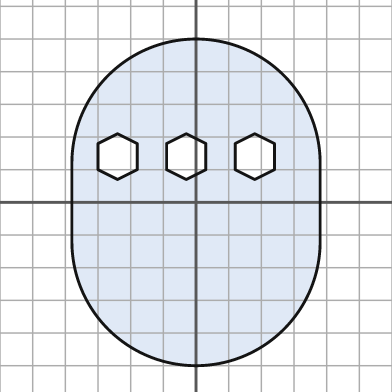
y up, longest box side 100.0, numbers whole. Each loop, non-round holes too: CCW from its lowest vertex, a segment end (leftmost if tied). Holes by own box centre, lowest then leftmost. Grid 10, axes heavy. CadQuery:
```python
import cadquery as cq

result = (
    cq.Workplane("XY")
    .moveTo(-38.0, -12.0)
    .threePointArc((0.0, -50.0), (38.0, -12.0))
    .lineTo(38.0, 12.0)
    .threePointArc((0.0, 50.0), (-38.0, 12.0))
    .close()
    .moveTo(-24.0, 7.0)
    .lineTo(-18.0, 10.0)
    .lineTo(-18.0, 18.0)
    .lineTo(-24.0, 21.0)
    .lineTo(-30.0, 18.0)
    .lineTo(-30.0, 10.0)
    .close()
    .moveTo(-3.0, 7.0)
    .lineTo(3.0, 10.0)
    .lineTo(3.0, 18.0)
    .lineTo(-3.0, 21.0)
    .lineTo(-9.0, 18.0)
    .lineTo(-9.0, 10.0)
    .close()
    .moveTo(18.0, 7.0)
    .lineTo(24.0, 10.0)
    .lineTo(24.0, 18.0)
    .lineTo(18.0, 21.0)
    .lineTo(12.0, 18.0)
    .lineTo(12.0, 10.0)
    .close()
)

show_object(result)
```